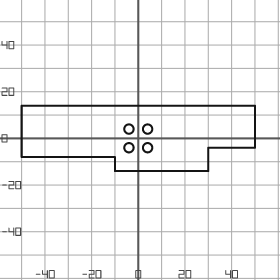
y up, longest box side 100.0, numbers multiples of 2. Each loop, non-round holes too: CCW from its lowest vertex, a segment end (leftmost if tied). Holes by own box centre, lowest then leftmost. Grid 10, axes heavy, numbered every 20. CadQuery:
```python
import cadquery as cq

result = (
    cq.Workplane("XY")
    .moveTo(-10.0, -14.0)
    .lineTo(30.0, -14.0)
    .lineTo(30.0, -4.0)
    .lineTo(50.0, -4.0)
    .lineTo(50.0, 14.0)
    .lineTo(-50.0, 14.0)
    .lineTo(-50.0, -8.0)
    .lineTo(-10.0, -8.0)
    .close()
    .moveTo(-4.0, -4.0)
    .circle(2.0)
    .moveTo(4.0, -4.0)
    .circle(2.0)
    .moveTo(-4.0, 4.0)
    .circle(2.0)
    .moveTo(4.0, 4.0)
    .circle(2.0)
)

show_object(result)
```